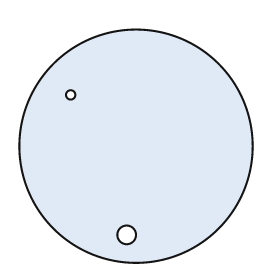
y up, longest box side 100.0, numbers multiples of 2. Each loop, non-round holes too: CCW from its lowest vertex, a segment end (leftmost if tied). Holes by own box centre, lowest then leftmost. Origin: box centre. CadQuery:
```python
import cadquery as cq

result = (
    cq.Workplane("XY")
    .moveTo(0.0, 0.0)
    .circle(50.0)
    .moveTo(-4.0, -38.0)
    .circle(4.0)
    .moveTo(-28.0, 22.0)
    .circle(2.0)
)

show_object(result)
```